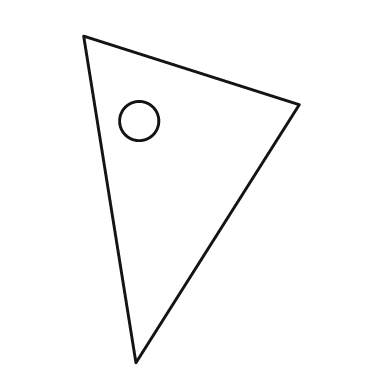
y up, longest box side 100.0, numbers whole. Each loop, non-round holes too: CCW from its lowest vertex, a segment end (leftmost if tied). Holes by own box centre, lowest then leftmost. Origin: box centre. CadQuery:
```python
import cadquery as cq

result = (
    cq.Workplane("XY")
    .moveTo(-17.0, -50.0)
    .lineTo(33.0, 29.0)
    .lineTo(-33.0, 50.0)
    .close()
    .moveTo(-16.0, 24.0)
    .circle(6.0)
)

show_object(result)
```